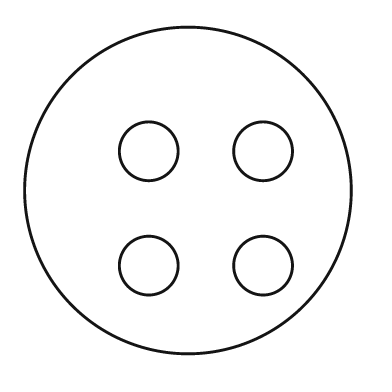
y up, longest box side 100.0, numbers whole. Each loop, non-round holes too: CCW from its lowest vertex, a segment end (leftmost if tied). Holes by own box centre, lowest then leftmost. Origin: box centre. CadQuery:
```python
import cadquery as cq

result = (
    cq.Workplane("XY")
    .moveTo(0.0, 0.0)
    .circle(50.0)
    .moveTo(-12.0, -23.0)
    .circle(9.0)
    .moveTo(23.0, -23.0)
    .circle(9.0)
    .moveTo(-12.0, 12.0)
    .circle(9.0)
    .moveTo(23.0, 12.0)
    .circle(9.0)
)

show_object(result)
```